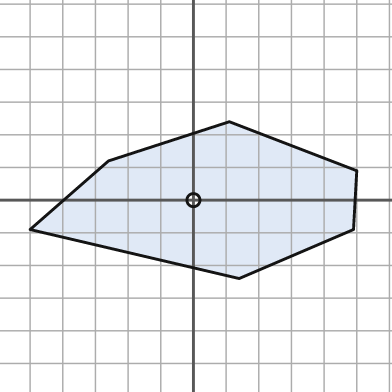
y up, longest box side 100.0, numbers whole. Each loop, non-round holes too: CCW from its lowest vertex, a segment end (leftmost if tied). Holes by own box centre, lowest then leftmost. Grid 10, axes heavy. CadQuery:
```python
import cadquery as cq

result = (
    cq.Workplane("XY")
    .moveTo(14.0, -24.0)
    .lineTo(49.0, -9.0)
    .lineTo(50.0, 9.0)
    .lineTo(11.0, 24.0)
    .lineTo(-26.0, 12.0)
    .lineTo(-50.0, -9.0)
    .close()
    .moveTo(0.0, 0.0)
    .circle(2.0)
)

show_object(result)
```